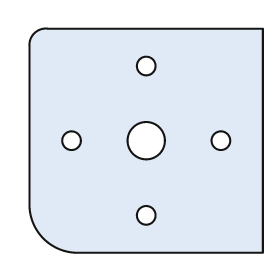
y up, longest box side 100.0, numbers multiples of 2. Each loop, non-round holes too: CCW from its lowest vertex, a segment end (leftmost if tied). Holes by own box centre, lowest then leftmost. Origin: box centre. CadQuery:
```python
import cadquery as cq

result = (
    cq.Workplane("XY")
    .moveTo(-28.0, -48.0)
    .lineTo(50.0, -48.0)
    .lineTo(50.0, 48.0)
    .lineTo(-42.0, 48.0)
    .threePointArc((-48.0, 46.0), (-50.0, 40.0))
    .lineTo(-50.0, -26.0)
    .threePointArc((-44.0, -42.0), (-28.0, -48.0))
    .close()
    .moveTo(0.0, -32.0)
    .circle(4.0)
    .moveTo(-32.0, 0.0)
    .circle(4.0)
    .moveTo(0.0, 0.0)
    .circle(8.0)
    .moveTo(32.0, 0.0)
    .circle(4.0)
    .moveTo(0.0, 32.0)
    .circle(4.0)
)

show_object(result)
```